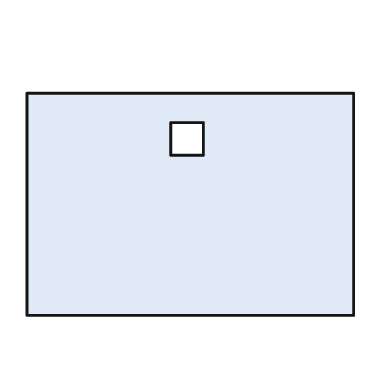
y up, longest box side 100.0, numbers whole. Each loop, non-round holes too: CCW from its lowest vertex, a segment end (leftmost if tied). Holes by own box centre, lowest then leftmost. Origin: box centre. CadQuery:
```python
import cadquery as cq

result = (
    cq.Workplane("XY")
    .moveTo(-50.0, -34.0)
    .lineTo(50.0, -34.0)
    .lineTo(50.0, 34.0)
    .lineTo(-50.0, 34.0)
    .close()
    .moveTo(-6.0, 15.0)
    .lineTo(4.0, 15.0)
    .lineTo(4.0, 25.0)
    .lineTo(-6.0, 25.0)
    .close()
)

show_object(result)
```